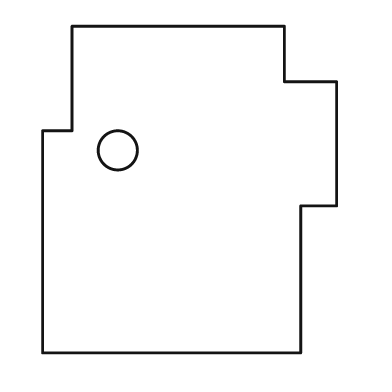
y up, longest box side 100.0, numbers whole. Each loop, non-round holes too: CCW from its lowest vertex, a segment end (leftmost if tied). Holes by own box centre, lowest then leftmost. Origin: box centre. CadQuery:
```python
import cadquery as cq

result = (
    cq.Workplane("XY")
    .moveTo(-45.0, -50.0)
    .lineTo(34.0, -50.0)
    .lineTo(34.0, -5.0)
    .lineTo(45.0, -5.0)
    .lineTo(45.0, 33.0)
    .lineTo(29.0, 33.0)
    .lineTo(29.0, 50.0)
    .lineTo(-36.0, 50.0)
    .lineTo(-36.0, 18.0)
    .lineTo(-45.0, 18.0)
    .close()
    .moveTo(-22.0, 12.0)
    .circle(6.0)
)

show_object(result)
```